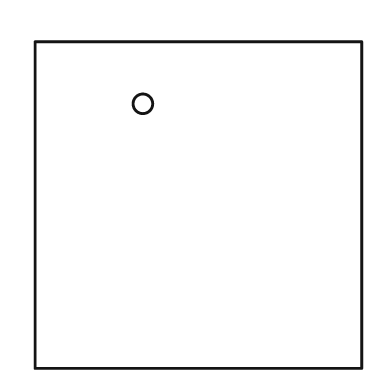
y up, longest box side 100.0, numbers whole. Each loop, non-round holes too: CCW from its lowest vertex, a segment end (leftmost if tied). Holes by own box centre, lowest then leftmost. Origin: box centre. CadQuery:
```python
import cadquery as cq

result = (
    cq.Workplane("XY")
    .moveTo(-50.0, -50.0)
    .lineTo(50.0, -50.0)
    .lineTo(50.0, 50.0)
    .lineTo(-50.0, 50.0)
    .close()
    .moveTo(-17.0, 31.0)
    .circle(3.0)
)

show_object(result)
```